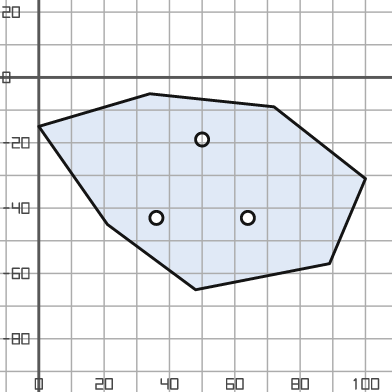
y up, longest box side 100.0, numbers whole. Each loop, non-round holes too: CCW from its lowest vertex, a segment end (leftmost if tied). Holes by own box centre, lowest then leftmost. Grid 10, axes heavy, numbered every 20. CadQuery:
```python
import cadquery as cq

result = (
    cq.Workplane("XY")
    .moveTo(48.0, -65.0)
    .lineTo(89.0, -57.0)
    .lineTo(100.0, -31.0)
    .lineTo(72.0, -9.0)
    .lineTo(34.0, -5.0)
    .lineTo(0.0, -15.0)
    .lineTo(21.0, -45.0)
    .close()
    .moveTo(36.0, -43.0)
    .circle(2.0)
    .moveTo(64.0, -43.0)
    .circle(2.0)
    .moveTo(50.0, -19.0)
    .circle(2.0)
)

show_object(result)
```